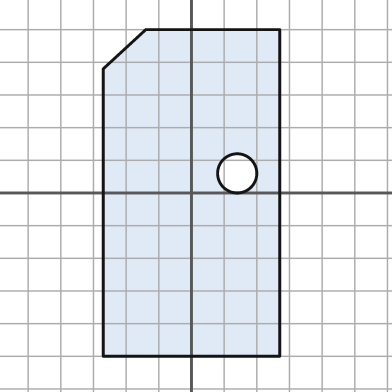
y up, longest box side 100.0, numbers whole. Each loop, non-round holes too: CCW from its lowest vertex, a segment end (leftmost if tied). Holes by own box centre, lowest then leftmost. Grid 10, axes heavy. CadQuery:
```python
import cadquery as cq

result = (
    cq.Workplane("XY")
    .moveTo(-27.0, -50.0)
    .lineTo(27.0, -50.0)
    .lineTo(27.0, 50.0)
    .lineTo(-14.0, 50.0)
    .lineTo(-27.0, 38.0)
    .close()
    .moveTo(14.0, 6.0)
    .circle(6.0)
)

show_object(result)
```